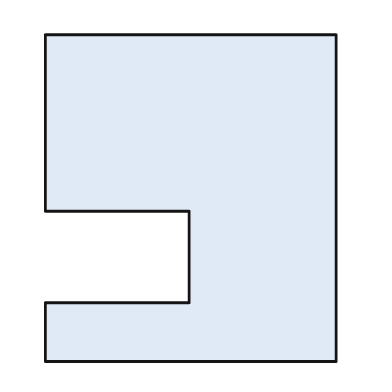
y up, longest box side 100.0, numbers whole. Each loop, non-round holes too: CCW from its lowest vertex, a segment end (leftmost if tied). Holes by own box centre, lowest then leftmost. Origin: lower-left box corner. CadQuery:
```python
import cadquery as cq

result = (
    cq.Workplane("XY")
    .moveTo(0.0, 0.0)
    .lineTo(89.0, 0.0)
    .lineTo(89.0, 100.0)
    .lineTo(0.0, 100.0)
    .lineTo(0.0, 46.0)
    .lineTo(44.0, 46.0)
    .lineTo(44.0, 18.0)
    .lineTo(0.0, 18.0)
    .close()
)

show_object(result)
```